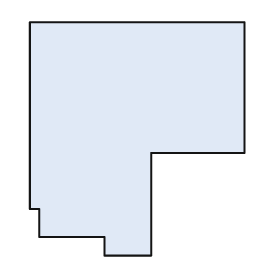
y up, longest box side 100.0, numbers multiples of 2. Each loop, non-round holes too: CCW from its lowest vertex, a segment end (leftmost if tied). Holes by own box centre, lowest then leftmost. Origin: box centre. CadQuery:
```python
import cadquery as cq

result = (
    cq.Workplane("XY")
    .moveTo(-14.0, -50.0)
    .lineTo(6.0, -50.0)
    .lineTo(6.0, -6.0)
    .lineTo(46.0, -6.0)
    .lineTo(46.0, 50.0)
    .lineTo(-46.0, 50.0)
    .lineTo(-46.0, -30.0)
    .lineTo(-42.0, -30.0)
    .lineTo(-42.0, -42.0)
    .lineTo(-14.0, -42.0)
    .close()
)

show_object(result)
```